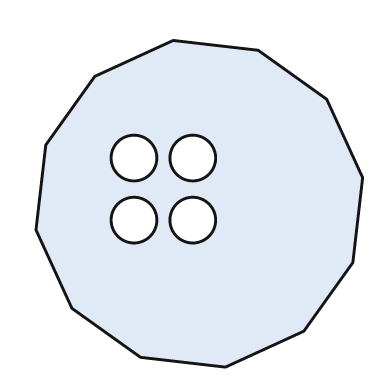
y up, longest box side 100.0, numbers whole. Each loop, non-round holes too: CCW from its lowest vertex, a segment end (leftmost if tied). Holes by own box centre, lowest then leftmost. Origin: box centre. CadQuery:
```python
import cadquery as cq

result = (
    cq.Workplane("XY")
    .moveTo(8.0, -50.0)
    .lineTo(32.0, -39.0)
    .lineTo(47.0, -18.0)
    .lineTo(50.0, 8.0)
    .lineTo(39.0, 32.0)
    .lineTo(18.0, 47.0)
    .lineTo(-8.0, 50.0)
    .lineTo(-32.0, 39.0)
    .lineTo(-47.0, 18.0)
    .lineTo(-50.0, -8.0)
    .lineTo(-39.0, -32.0)
    .lineTo(-18.0, -47.0)
    .close()
    .moveTo(-20.0, -5.0)
    .circle(7.0)
    .moveTo(-2.0, -5.0)
    .circle(7.0)
    .moveTo(-20.0, 14.0)
    .circle(7.0)
    .moveTo(-2.0, 14.0)
    .circle(7.0)
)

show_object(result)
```